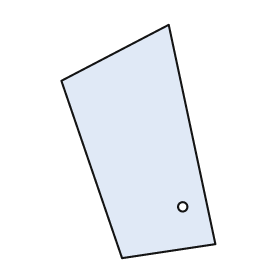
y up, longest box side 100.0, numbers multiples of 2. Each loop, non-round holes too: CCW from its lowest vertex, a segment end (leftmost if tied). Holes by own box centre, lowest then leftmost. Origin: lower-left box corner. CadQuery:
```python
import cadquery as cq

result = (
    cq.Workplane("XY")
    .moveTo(26.0, 0.0)
    .lineTo(66.0, 6.0)
    .lineTo(46.0, 100.0)
    .lineTo(0.0, 76.0)
    .close()
    .moveTo(52.0, 22.0)
    .circle(2.0)
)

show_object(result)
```